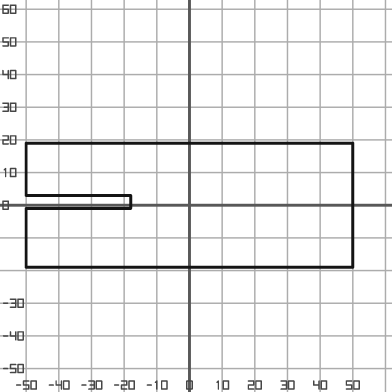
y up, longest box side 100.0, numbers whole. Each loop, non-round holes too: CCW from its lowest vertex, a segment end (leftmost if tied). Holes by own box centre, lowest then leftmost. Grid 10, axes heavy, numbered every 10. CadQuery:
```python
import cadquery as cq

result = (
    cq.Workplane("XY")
    .moveTo(-50.0, -19.0)
    .lineTo(50.0, -19.0)
    .lineTo(50.0, 19.0)
    .lineTo(-50.0, 19.0)
    .lineTo(-50.0, 3.0)
    .lineTo(-18.0, 3.0)
    .lineTo(-18.0, -1.0)
    .lineTo(-50.0, -1.0)
    .close()
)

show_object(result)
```